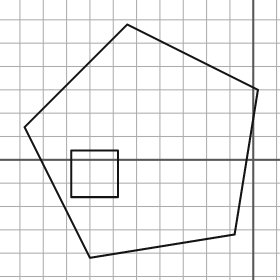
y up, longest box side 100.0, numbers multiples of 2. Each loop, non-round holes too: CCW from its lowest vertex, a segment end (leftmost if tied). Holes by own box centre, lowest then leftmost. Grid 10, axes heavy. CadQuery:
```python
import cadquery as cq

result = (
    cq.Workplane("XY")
    .moveTo(-70.0, -42.0)
    .lineTo(-8.0, -32.0)
    .lineTo(2.0, 30.0)
    .lineTo(-54.0, 58.0)
    .lineTo(-98.0, 14.0)
    .close()
    .moveTo(-78.0, -16.0)
    .lineTo(-58.0, -16.0)
    .lineTo(-58.0, 4.0)
    .lineTo(-78.0, 4.0)
    .close()
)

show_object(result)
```